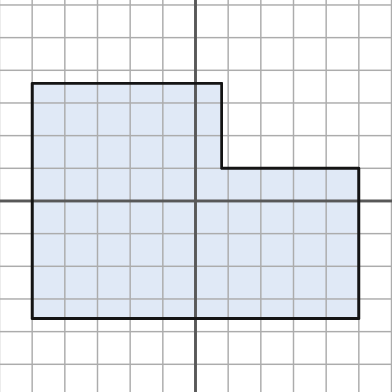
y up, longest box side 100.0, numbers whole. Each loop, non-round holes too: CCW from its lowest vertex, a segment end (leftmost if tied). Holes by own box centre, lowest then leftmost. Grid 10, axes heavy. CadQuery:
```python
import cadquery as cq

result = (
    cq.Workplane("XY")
    .moveTo(-50.0, -36.0)
    .lineTo(50.0, -36.0)
    .lineTo(50.0, 10.0)
    .lineTo(8.0, 10.0)
    .lineTo(8.0, 36.0)
    .lineTo(-50.0, 36.0)
    .close()
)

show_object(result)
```